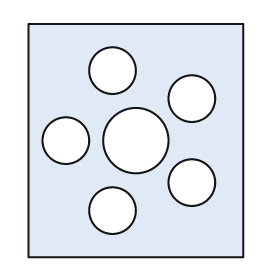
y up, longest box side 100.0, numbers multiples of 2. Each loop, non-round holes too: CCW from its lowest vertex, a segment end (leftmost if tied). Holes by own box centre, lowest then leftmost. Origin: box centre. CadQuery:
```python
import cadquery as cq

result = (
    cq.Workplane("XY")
    .moveTo(-46.0, -50.0)
    .lineTo(46.0, -50.0)
    .lineTo(46.0, 50.0)
    .lineTo(-46.0, 50.0)
    .close()
    .moveTo(-10.0, -30.0)
    .circle(10.0)
    .moveTo(24.0, -18.0)
    .circle(10.0)
    .moveTo(-30.0, 0.0)
    .circle(10.0)
    .moveTo(0.0, 0.0)
    .circle(14.0)
    .moveTo(24.0, 18.0)
    .circle(10.0)
    .moveTo(-10.0, 30.0)
    .circle(10.0)
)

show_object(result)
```